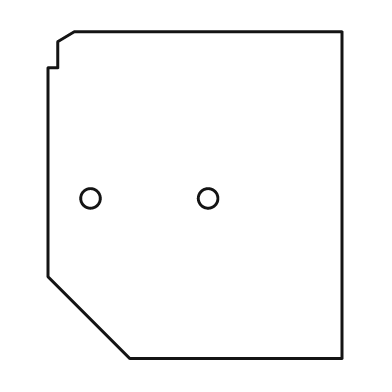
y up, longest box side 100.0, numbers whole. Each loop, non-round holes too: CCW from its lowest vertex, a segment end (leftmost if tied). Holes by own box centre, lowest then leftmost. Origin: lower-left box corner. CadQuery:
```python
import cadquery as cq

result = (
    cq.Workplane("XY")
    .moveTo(25.0, 0.0)
    .lineTo(90.0, 0.0)
    .lineTo(90.0, 100.0)
    .lineTo(8.0, 100.0)
    .lineTo(3.0, 97.0)
    .lineTo(3.0, 89.0)
    .lineTo(0.0, 89.0)
    .lineTo(0.0, 25.0)
    .close()
    .moveTo(13.0, 49.0)
    .circle(3.0)
    .moveTo(49.0, 49.0)
    .circle(3.0)
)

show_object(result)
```